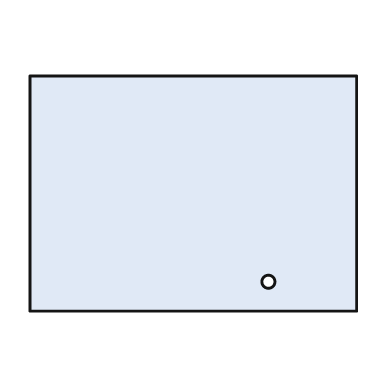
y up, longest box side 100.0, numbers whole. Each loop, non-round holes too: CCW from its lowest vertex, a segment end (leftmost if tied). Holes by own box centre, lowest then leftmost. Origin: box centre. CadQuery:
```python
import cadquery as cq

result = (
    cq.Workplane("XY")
    .moveTo(-50.0, -36.0)
    .lineTo(50.0, -36.0)
    .lineTo(50.0, 36.0)
    .lineTo(-50.0, 36.0)
    .close()
    .moveTo(23.0, -27.0)
    .circle(2.0)
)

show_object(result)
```